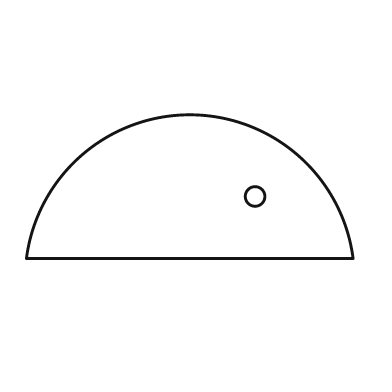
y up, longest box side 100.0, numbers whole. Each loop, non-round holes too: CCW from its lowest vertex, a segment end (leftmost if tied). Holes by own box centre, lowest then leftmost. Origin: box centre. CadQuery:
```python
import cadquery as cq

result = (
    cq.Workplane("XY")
    .moveTo(-50.0, -22.0)
    .lineTo(50.0, -22.0)
    .threePointArc((0.0, 22.0), (-50.0, -22.0))
    .close()
    .moveTo(20.0, -3.0)
    .circle(3.0)
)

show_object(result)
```